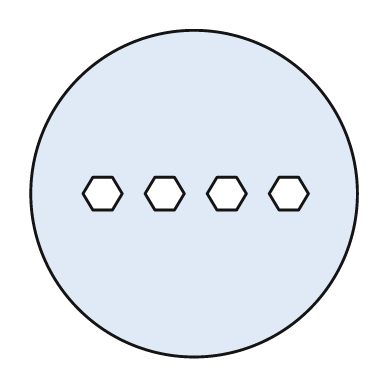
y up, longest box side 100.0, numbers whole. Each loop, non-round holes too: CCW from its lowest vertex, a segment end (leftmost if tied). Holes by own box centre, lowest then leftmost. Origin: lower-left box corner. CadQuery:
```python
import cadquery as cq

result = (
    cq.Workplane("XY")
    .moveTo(50.0, 50.0)
    .circle(50.0)
    .moveTo(19.0, 45.0)
    .lineTo(25.0, 45.0)
    .lineTo(28.0, 50.0)
    .lineTo(25.0, 55.0)
    .lineTo(19.0, 55.0)
    .lineTo(16.0, 50.0)
    .close()
    .moveTo(38.0, 45.0)
    .lineTo(44.0, 45.0)
    .lineTo(47.0, 50.0)
    .lineTo(44.0, 55.0)
    .lineTo(38.0, 55.0)
    .lineTo(35.0, 50.0)
    .close()
    .moveTo(57.0, 45.0)
    .lineTo(63.0, 45.0)
    .lineTo(66.0, 50.0)
    .lineTo(63.0, 55.0)
    .lineTo(57.0, 55.0)
    .lineTo(54.0, 50.0)
    .close()
    .moveTo(76.0, 45.0)
    .lineTo(82.0, 45.0)
    .lineTo(85.0, 50.0)
    .lineTo(82.0, 55.0)
    .lineTo(76.0, 55.0)
    .lineTo(73.0, 50.0)
    .close()
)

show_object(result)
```